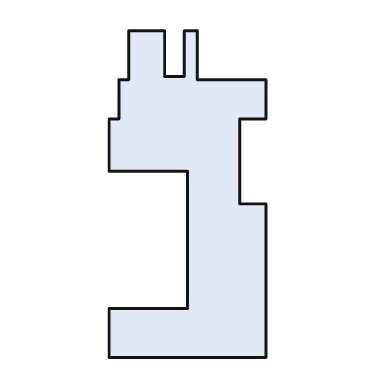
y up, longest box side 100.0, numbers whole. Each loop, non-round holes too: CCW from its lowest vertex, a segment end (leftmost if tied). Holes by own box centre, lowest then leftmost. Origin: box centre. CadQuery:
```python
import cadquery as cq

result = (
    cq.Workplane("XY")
    .moveTo(-24.0, -50.0)
    .lineTo(24.0, -50.0)
    .lineTo(24.0, -3.0)
    .lineTo(16.0, -3.0)
    .lineTo(16.0, 23.0)
    .lineTo(24.0, 23.0)
    .lineTo(24.0, 35.0)
    .lineTo(3.0, 35.0)
    .lineTo(3.0, 50.0)
    .lineTo(-1.0, 50.0)
    .lineTo(-1.0, 36.0)
    .lineTo(-7.0, 36.0)
    .lineTo(-7.0, 50.0)
    .lineTo(-18.0, 50.0)
    .lineTo(-18.0, 35.0)
    .lineTo(-21.0, 35.0)
    .lineTo(-21.0, 23.0)
    .lineTo(-24.0, 23.0)
    .lineTo(-24.0, 7.0)
    .lineTo(0.0, 7.0)
    .lineTo(0.0, -35.0)
    .lineTo(-24.0, -35.0)
    .close()
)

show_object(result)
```